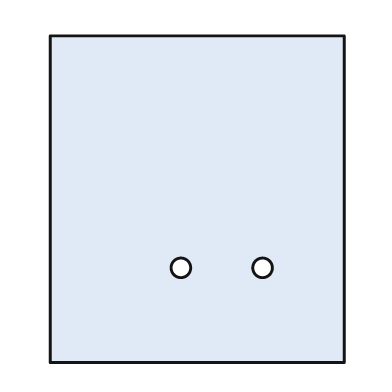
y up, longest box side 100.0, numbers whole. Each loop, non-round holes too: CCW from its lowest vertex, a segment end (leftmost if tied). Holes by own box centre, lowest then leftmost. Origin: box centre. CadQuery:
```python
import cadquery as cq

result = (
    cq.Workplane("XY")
    .moveTo(-45.0, -50.0)
    .lineTo(45.0, -50.0)
    .lineTo(45.0, 50.0)
    .lineTo(-45.0, 50.0)
    .close()
    .moveTo(-5.0, -21.0)
    .circle(3.0)
    .moveTo(20.0, -21.0)
    .circle(3.0)
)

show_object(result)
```